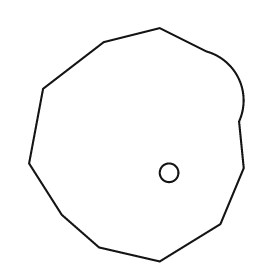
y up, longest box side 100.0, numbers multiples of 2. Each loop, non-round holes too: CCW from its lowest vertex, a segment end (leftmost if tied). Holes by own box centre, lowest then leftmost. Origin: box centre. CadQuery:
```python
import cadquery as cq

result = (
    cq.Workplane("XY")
    .moveTo(10.0, -50.0)
    .lineTo(36.0, -34.0)
    .lineTo(46.0, -10.0)
    .lineTo(44.0, 10.0)
    .threePointArc((44.0, 28.0), (30.0, 40.0))
    .lineTo(10.0, 50.0)
    .lineTo(-14.0, 44.0)
    .lineTo(-40.0, 24.0)
    .lineTo(-46.0, -8.0)
    .lineTo(-32.0, -30.0)
    .lineTo(-16.0, -44.0)
    .close()
    .moveTo(14.0, -12.0)
    .circle(4.0)
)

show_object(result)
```